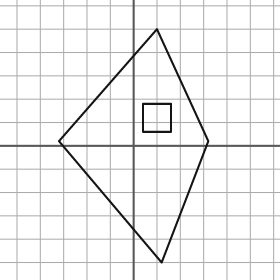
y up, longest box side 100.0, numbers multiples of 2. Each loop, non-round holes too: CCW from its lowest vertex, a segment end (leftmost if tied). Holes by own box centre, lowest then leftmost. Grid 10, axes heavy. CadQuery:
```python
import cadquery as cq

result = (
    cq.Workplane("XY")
    .moveTo(12.0, -50.0)
    .lineTo(32.0, 2.0)
    .lineTo(10.0, 50.0)
    .lineTo(-32.0, 2.0)
    .close()
    .moveTo(4.0, 6.0)
    .lineTo(16.0, 6.0)
    .lineTo(16.0, 18.0)
    .lineTo(4.0, 18.0)
    .close()
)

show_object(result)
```